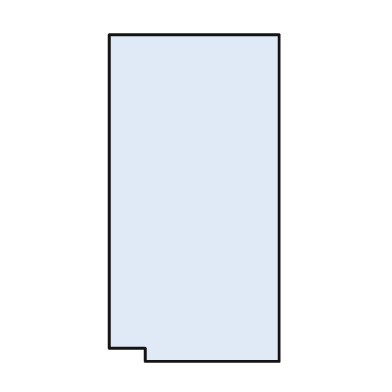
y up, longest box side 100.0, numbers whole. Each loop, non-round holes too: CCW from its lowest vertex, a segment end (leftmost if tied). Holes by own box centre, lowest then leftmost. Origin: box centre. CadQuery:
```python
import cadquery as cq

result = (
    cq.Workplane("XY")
    .moveTo(-15.0, -50.0)
    .lineTo(26.0, -50.0)
    .lineTo(26.0, 50.0)
    .lineTo(-26.0, 50.0)
    .lineTo(-26.0, -46.0)
    .lineTo(-15.0, -46.0)
    .close()
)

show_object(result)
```